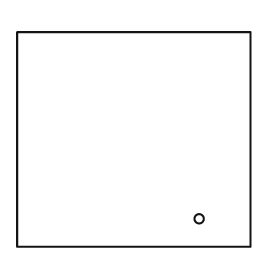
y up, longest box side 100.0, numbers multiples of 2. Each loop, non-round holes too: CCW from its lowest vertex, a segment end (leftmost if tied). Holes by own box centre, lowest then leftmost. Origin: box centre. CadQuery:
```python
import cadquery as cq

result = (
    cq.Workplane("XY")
    .moveTo(-50.0, -46.0)
    .lineTo(50.0, -46.0)
    .lineTo(50.0, 46.0)
    .lineTo(-50.0, 46.0)
    .close()
    .moveTo(28.0, -34.0)
    .circle(2.0)
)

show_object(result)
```